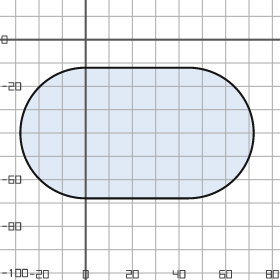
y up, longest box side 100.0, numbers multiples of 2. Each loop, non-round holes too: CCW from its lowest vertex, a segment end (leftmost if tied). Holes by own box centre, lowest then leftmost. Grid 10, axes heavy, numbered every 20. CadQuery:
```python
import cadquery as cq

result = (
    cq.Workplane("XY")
    .moveTo(0.0, -68.0)
    .lineTo(44.0, -68.0)
    .threePointArc((72.0, -40.0), (44.0, -12.0))
    .lineTo(0.0, -12.0)
    .threePointArc((-28.0, -40.0), (0.0, -68.0))
    .close()
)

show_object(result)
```